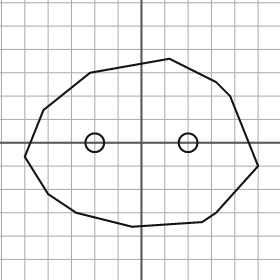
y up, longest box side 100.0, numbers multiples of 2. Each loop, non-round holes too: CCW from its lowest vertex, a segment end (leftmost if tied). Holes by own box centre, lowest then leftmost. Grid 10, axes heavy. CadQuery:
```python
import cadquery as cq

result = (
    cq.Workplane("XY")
    .moveTo(-4.0, -36.0)
    .lineTo(26.0, -34.0)
    .lineTo(32.0, -30.0)
    .lineTo(50.0, -10.0)
    .lineTo(38.0, 20.0)
    .lineTo(32.0, 26.0)
    .lineTo(12.0, 36.0)
    .lineTo(-22.0, 30.0)
    .lineTo(-42.0, 14.0)
    .lineTo(-50.0, -6.0)
    .lineTo(-40.0, -22.0)
    .lineTo(-28.0, -30.0)
    .close()
    .moveTo(-20.0, 0.0)
    .circle(4.0)
    .moveTo(20.0, 0.0)
    .circle(4.0)
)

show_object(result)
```